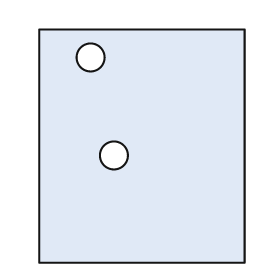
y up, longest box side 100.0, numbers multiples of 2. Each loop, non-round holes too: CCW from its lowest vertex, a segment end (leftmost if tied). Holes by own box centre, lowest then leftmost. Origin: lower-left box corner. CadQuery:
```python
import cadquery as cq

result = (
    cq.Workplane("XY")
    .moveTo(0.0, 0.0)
    .lineTo(88.0, 0.0)
    .lineTo(88.0, 100.0)
    .lineTo(0.0, 100.0)
    .close()
    .moveTo(32.0, 46.0)
    .circle(6.0)
    .moveTo(22.0, 88.0)
    .circle(6.0)
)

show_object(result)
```